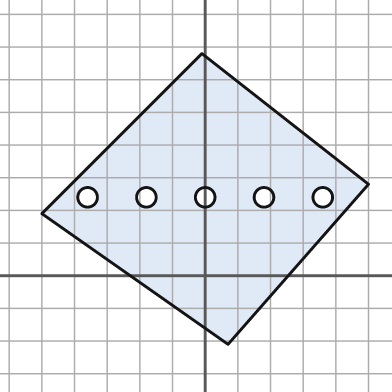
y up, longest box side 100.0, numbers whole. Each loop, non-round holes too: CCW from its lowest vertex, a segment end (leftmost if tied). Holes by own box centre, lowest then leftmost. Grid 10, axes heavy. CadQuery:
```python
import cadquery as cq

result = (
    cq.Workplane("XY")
    .moveTo(7.0, -21.0)
    .lineTo(50.0, 28.0)
    .lineTo(-1.0, 68.0)
    .lineTo(-50.0, 19.0)
    .close()
    .moveTo(-36.0, 24.0)
    .circle(3.0)
    .moveTo(-18.0, 24.0)
    .circle(3.0)
    .moveTo(0.0, 24.0)
    .circle(3.0)
    .moveTo(18.0, 24.0)
    .circle(3.0)
    .moveTo(36.0, 24.0)
    .circle(3.0)
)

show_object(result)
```